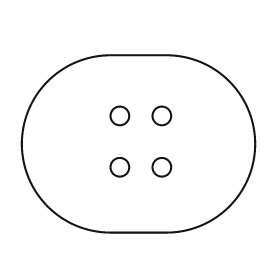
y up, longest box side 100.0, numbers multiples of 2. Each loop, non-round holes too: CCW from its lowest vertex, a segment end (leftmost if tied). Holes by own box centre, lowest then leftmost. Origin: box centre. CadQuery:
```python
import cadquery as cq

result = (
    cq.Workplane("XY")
    .moveTo(-12.0, -38.0)
    .lineTo(12.0, -38.0)
    .threePointArc((50.0, 0.0), (12.0, 38.0))
    .lineTo(-12.0, 38.0)
    .threePointArc((-50.0, 0.0), (-12.0, -38.0))
    .close()
    .moveTo(-8.0, -10.0)
    .circle(4.0)
    .moveTo(10.0, -10.0)
    .circle(4.0)
    .moveTo(-8.0, 12.0)
    .circle(4.0)
    .moveTo(10.0, 12.0)
    .circle(4.0)
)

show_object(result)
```